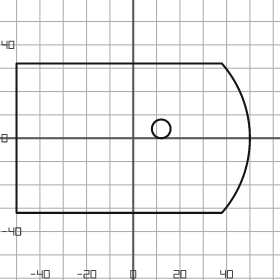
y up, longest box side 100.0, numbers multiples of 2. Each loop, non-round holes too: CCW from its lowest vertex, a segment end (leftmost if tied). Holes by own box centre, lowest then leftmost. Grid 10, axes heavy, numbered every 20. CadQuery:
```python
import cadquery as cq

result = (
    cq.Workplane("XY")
    .moveTo(-50.0, -32.0)
    .lineTo(38.0, -32.0)
    .threePointArc((50.0, 0.0), (38.0, 32.0))
    .lineTo(-50.0, 32.0)
    .close()
    .moveTo(12.0, 4.0)
    .circle(4.0)
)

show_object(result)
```